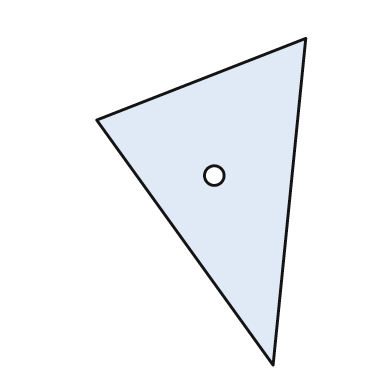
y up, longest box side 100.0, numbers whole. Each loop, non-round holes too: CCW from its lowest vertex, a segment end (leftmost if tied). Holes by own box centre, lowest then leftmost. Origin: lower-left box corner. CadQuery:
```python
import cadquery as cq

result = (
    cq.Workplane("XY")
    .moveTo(54.0, 0.0)
    .lineTo(64.0, 100.0)
    .lineTo(0.0, 75.0)
    .close()
    .moveTo(36.0, 58.0)
    .circle(3.0)
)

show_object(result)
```